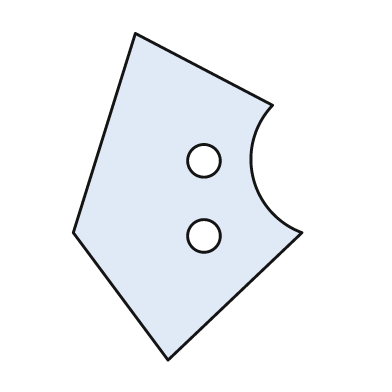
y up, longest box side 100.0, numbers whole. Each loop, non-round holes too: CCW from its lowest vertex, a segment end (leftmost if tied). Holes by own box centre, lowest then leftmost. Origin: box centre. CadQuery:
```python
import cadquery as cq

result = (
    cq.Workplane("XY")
    .moveTo(-6.0, -50.0)
    .lineTo(35.0, -11.0)
    .threePointArc((20.0, 6.0), (26.0, 28.0))
    .lineTo(-16.0, 50.0)
    .lineTo(-35.0, -11.0)
    .close()
    .moveTo(5.0, -12.0)
    .circle(5.0)
    .moveTo(5.0, 11.0)
    .circle(5.0)
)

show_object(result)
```